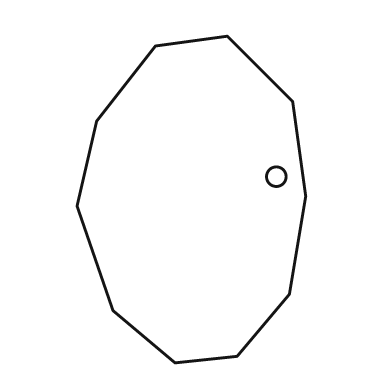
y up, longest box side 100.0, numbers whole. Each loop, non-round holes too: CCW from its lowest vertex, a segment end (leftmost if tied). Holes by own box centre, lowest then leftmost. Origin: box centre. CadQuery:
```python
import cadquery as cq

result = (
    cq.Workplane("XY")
    .moveTo(-5.0, -50.0)
    .lineTo(14.0, -48.0)
    .lineTo(30.0, -29.0)
    .lineTo(35.0, 1.0)
    .lineTo(31.0, 30.0)
    .lineTo(11.0, 50.0)
    .lineTo(-11.0, 47.0)
    .lineTo(-29.0, 24.0)
    .lineTo(-35.0, -2.0)
    .lineTo(-24.0, -34.0)
    .close()
    .moveTo(26.0, 7.0)
    .circle(3.0)
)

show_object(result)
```